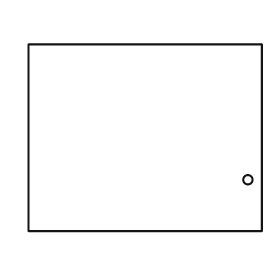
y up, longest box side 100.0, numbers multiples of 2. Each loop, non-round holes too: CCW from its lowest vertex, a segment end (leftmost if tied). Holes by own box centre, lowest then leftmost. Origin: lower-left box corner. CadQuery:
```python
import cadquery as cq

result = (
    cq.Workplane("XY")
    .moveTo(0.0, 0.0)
    .lineTo(100.0, 0.0)
    .lineTo(100.0, 80.0)
    .lineTo(0.0, 80.0)
    .close()
    .moveTo(94.0, 22.0)
    .circle(2.0)
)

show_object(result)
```